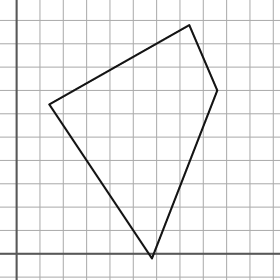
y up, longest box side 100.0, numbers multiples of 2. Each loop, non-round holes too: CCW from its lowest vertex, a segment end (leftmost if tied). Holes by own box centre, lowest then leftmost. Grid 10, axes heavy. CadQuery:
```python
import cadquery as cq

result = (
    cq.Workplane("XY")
    .moveTo(58.0, -2.0)
    .lineTo(86.0, 70.0)
    .lineTo(74.0, 98.0)
    .lineTo(14.0, 64.0)
    .close()
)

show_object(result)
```